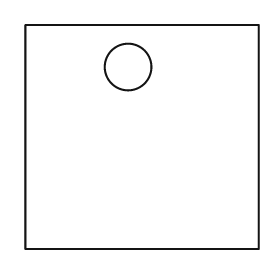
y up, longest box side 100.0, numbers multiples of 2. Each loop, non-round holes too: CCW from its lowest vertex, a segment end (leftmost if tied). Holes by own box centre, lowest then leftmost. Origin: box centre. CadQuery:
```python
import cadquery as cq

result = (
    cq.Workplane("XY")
    .moveTo(-50.0, -48.0)
    .lineTo(50.0, -48.0)
    .lineTo(50.0, 48.0)
    .lineTo(-50.0, 48.0)
    .close()
    .moveTo(-6.0, 30.0)
    .circle(10.0)
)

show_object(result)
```